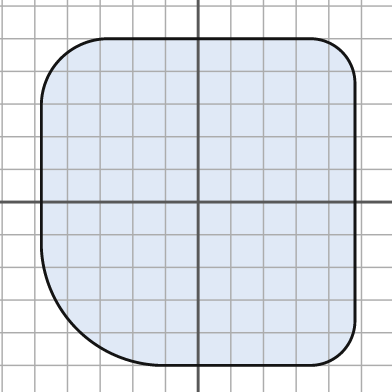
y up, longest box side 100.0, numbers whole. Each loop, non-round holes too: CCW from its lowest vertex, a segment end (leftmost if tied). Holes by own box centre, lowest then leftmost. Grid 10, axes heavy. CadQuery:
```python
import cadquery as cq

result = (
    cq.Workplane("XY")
    .moveTo(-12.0, -50.0)
    .lineTo(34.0, -50.0)
    .threePointArc((44.0, -46.0), (48.0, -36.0))
    .lineTo(48.0, 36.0)
    .threePointArc((44.0, 46.0), (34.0, 50.0))
    .lineTo(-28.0, 50.0)
    .threePointArc((-42.0, 44.0), (-48.0, 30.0))
    .lineTo(-48.0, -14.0)
    .threePointArc((-37.0, -39.0), (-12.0, -50.0))
    .close()
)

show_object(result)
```